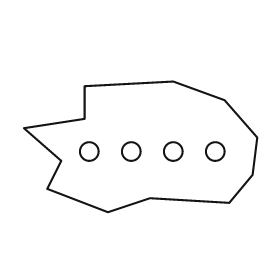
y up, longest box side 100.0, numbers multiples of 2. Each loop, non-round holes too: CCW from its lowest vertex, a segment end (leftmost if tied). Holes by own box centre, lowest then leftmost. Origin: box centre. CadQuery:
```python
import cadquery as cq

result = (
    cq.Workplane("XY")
    .moveTo(-14.0, -28.0)
    .lineTo(4.0, -22.0)
    .lineTo(38.0, -24.0)
    .lineTo(48.0, -12.0)
    .lineTo(50.0, 4.0)
    .lineTo(36.0, 20.0)
    .lineTo(14.0, 28.0)
    .lineTo(-24.0, 26.0)
    .lineTo(-24.0, 12.0)
    .lineTo(-50.0, 8.0)
    .lineTo(-34.0, -6.0)
    .lineTo(-40.0, -18.0)
    .close()
    .moveTo(-22.0, -2.0)
    .circle(4.0)
    .moveTo(-4.0, -2.0)
    .circle(4.0)
    .moveTo(14.0, -2.0)
    .circle(4.0)
    .moveTo(32.0, -2.0)
    .circle(4.0)
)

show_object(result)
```